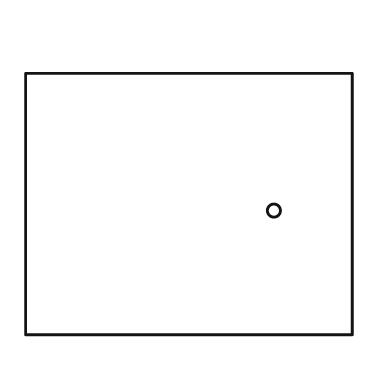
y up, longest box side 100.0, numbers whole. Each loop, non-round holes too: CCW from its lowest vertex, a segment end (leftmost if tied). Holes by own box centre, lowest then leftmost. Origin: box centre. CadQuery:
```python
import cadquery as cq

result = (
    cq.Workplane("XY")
    .moveTo(-50.0, -40.0)
    .lineTo(50.0, -40.0)
    .lineTo(50.0, 40.0)
    .lineTo(-50.0, 40.0)
    .close()
    .moveTo(26.0, -2.0)
    .circle(2.0)
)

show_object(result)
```